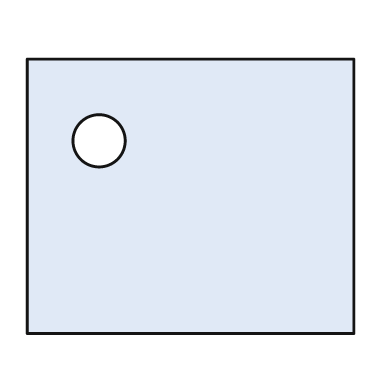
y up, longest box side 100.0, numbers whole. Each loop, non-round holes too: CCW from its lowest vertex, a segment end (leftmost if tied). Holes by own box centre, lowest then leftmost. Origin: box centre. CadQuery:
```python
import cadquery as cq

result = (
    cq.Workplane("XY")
    .moveTo(-50.0, -42.0)
    .lineTo(50.0, -42.0)
    .lineTo(50.0, 42.0)
    .lineTo(-50.0, 42.0)
    .close()
    .moveTo(-28.0, 17.0)
    .circle(8.0)
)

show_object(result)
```